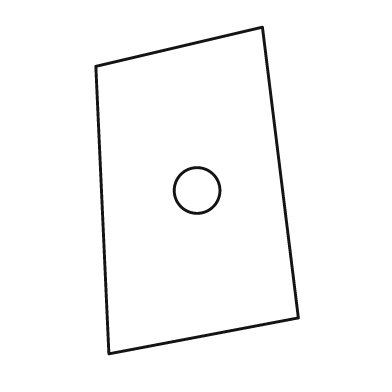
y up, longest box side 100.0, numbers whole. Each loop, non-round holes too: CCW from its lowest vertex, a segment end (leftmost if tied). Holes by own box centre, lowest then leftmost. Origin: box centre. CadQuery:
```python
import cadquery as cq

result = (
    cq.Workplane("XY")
    .moveTo(-27.0, -50.0)
    .lineTo(31.0, -39.0)
    .lineTo(20.0, 50.0)
    .lineTo(-31.0, 38.0)
    .close()
    .moveTo(0.0, 0.0)
    .circle(7.0)
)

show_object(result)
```